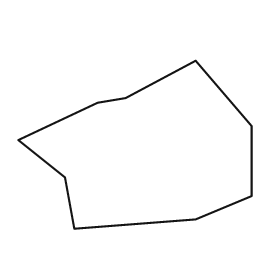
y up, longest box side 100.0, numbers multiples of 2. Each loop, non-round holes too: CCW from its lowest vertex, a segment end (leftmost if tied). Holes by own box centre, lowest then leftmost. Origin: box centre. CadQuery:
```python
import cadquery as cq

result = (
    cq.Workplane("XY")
    .moveTo(-26.0, -36.0)
    .lineTo(26.0, -32.0)
    .lineTo(50.0, -22.0)
    .lineTo(50.0, 8.0)
    .lineTo(26.0, 36.0)
    .lineTo(-4.0, 20.0)
    .lineTo(-16.0, 18.0)
    .lineTo(-50.0, 2.0)
    .lineTo(-30.0, -14.0)
    .close()
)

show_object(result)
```